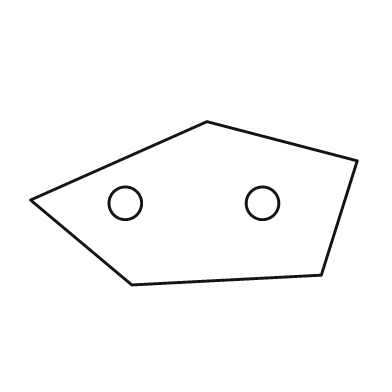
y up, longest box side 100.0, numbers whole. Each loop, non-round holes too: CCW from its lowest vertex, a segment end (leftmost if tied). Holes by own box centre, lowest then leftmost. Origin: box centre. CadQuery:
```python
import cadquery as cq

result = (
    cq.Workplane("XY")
    .moveTo(-19.0, -25.0)
    .lineTo(39.0, -22.0)
    .lineTo(50.0, 13.0)
    .lineTo(4.0, 25.0)
    .lineTo(-50.0, 1.0)
    .close()
    .moveTo(-21.0, 0.0)
    .circle(5.0)
    .moveTo(21.0, 0.0)
    .circle(5.0)
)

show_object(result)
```